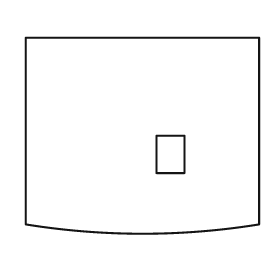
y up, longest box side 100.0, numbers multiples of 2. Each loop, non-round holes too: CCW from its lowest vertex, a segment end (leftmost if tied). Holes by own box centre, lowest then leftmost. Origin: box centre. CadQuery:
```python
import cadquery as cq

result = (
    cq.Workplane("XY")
    .moveTo(-50.0, -38.0)
    .threePointArc((0.0, -42.0), (50.0, -38.0))
    .lineTo(50.0, 42.0)
    .lineTo(-50.0, 42.0)
    .close()
    .moveTo(6.0, -16.0)
    .lineTo(18.0, -16.0)
    .lineTo(18.0, 0.0)
    .lineTo(6.0, 0.0)
    .close()
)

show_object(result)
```